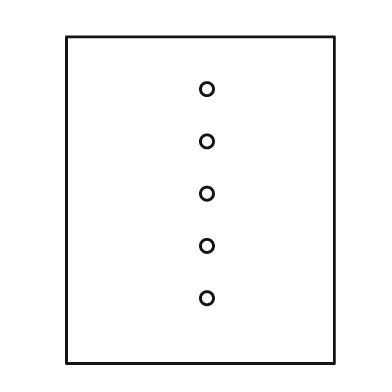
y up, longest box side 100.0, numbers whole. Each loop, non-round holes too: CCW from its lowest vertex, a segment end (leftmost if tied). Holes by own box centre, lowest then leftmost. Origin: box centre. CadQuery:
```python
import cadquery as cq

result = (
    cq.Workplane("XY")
    .moveTo(-41.0, -50.0)
    .lineTo(41.0, -50.0)
    .lineTo(41.0, 50.0)
    .lineTo(-41.0, 50.0)
    .close()
    .moveTo(2.0, -30.0)
    .circle(2.0)
    .moveTo(2.0, -14.0)
    .circle(2.0)
    .moveTo(2.0, 2.0)
    .circle(2.0)
    .moveTo(2.0, 18.0)
    .circle(2.0)
    .moveTo(2.0, 34.0)
    .circle(2.0)
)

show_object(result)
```